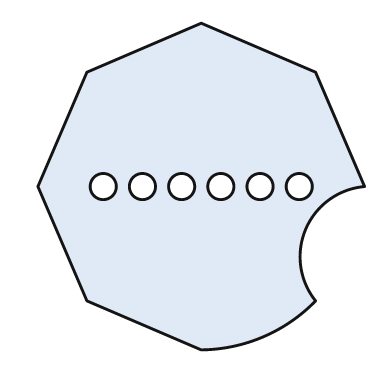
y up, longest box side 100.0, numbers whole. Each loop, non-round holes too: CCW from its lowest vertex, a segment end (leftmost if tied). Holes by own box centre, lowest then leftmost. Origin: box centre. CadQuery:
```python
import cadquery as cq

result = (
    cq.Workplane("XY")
    .moveTo(0.0, -50.0)
    .threePointArc((19.0, -46.0), (35.0, -35.0))
    .threePointArc((32.0, -13.0), (50.0, 0.0))
    .lineTo(35.0, 35.0)
    .lineTo(0.0, 50.0)
    .lineTo(-35.0, 35.0)
    .lineTo(-50.0, 0.0)
    .lineTo(-35.0, -35.0)
    .close()
    .moveTo(-30.0, 0.0)
    .circle(4.0)
    .moveTo(-18.0, 0.0)
    .circle(4.0)
    .moveTo(-6.0, 0.0)
    .circle(4.0)
    .moveTo(6.0, 0.0)
    .circle(4.0)
    .moveTo(18.0, 0.0)
    .circle(4.0)
    .moveTo(30.0, 0.0)
    .circle(4.0)
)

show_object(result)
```